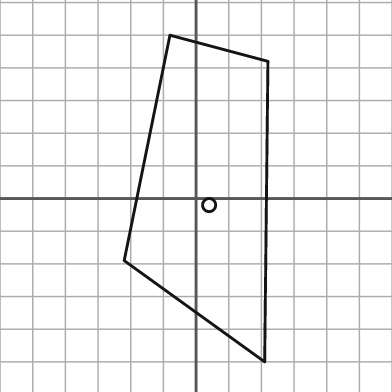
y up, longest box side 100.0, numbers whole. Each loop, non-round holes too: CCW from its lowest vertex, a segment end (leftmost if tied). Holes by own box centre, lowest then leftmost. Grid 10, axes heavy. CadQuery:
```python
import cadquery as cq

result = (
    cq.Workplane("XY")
    .moveTo(21.0, -50.0)
    .lineTo(22.0, 42.0)
    .lineTo(-8.0, 50.0)
    .lineTo(-22.0, -19.0)
    .close()
    .moveTo(4.0, -2.0)
    .circle(2.0)
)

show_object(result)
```